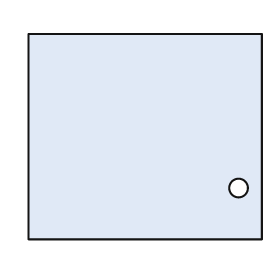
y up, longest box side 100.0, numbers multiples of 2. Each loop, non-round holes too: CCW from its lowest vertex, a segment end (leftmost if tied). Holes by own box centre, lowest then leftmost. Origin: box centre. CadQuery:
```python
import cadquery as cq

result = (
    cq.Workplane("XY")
    .moveTo(-50.0, -44.0)
    .lineTo(50.0, -44.0)
    .lineTo(50.0, 44.0)
    .lineTo(-50.0, 44.0)
    .close()
    .moveTo(40.0, -22.0)
    .circle(4.0)
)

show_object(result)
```